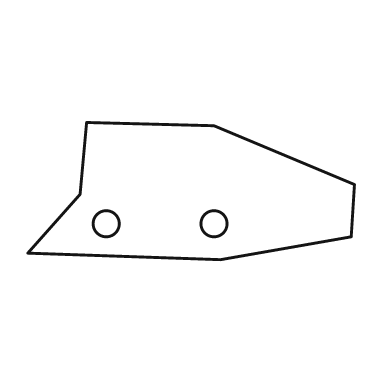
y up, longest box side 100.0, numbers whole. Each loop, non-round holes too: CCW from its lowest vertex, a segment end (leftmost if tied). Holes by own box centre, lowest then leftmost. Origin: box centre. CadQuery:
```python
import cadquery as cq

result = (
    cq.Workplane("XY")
    .moveTo(9.0, -21.0)
    .lineTo(49.0, -14.0)
    .lineTo(50.0, 2.0)
    .lineTo(7.0, 20.0)
    .lineTo(-32.0, 21.0)
    .lineTo(-34.0, -1.0)
    .lineTo(-50.0, -19.0)
    .close()
    .moveTo(-26.0, -10.0)
    .circle(4.0)
    .moveTo(7.0, -10.0)
    .circle(4.0)
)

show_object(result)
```